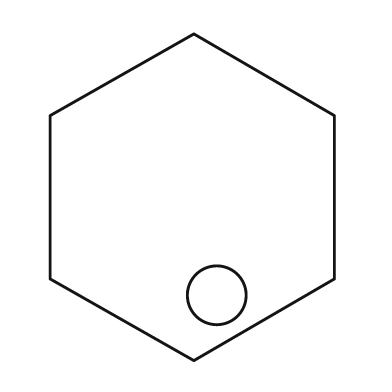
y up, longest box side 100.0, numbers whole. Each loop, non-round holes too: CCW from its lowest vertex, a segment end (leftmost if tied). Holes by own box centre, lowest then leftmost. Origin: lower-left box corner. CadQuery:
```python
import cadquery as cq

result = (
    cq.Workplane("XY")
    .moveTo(44.0, 0.0)
    .lineTo(87.0, 25.0)
    .lineTo(87.0, 75.0)
    .lineTo(44.0, 100.0)
    .lineTo(0.0, 75.0)
    .lineTo(0.0, 25.0)
    .close()
    .moveTo(51.0, 20.0)
    .circle(9.0)
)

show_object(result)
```